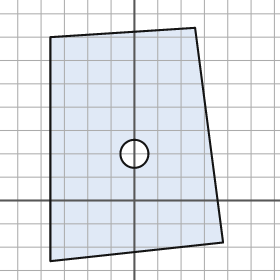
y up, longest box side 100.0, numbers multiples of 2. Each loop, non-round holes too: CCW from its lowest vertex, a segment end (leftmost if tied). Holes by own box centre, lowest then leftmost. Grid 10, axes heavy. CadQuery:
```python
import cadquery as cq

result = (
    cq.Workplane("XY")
    .moveTo(-36.0, -26.0)
    .lineTo(38.0, -18.0)
    .lineTo(26.0, 74.0)
    .lineTo(-36.0, 70.0)
    .close()
    .moveTo(0.0, 20.0)
    .circle(6.0)
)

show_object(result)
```